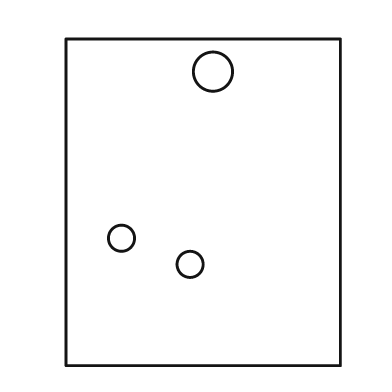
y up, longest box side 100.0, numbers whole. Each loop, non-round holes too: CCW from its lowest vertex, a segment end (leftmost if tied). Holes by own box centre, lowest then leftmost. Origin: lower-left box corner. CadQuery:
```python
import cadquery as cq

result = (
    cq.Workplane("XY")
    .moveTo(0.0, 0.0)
    .lineTo(84.0, 0.0)
    .lineTo(84.0, 100.0)
    .lineTo(0.0, 100.0)
    .close()
    .moveTo(38.0, 31.0)
    .circle(4.0)
    .moveTo(17.0, 39.0)
    .circle(4.0)
    .moveTo(45.0, 90.0)
    .circle(6.0)
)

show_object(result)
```